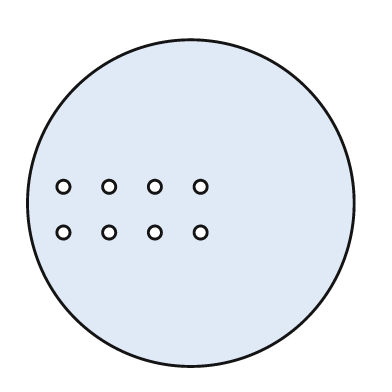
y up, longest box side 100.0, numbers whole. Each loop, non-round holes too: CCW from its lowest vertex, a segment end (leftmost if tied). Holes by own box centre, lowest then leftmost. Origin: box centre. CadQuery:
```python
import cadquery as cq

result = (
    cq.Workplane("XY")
    .moveTo(0.0, 0.0)
    .circle(50.0)
    .moveTo(-39.0, -9.0)
    .circle(2.0)
    .moveTo(-25.0, -9.0)
    .circle(2.0)
    .moveTo(-11.0, -9.0)
    .circle(2.0)
    .moveTo(3.0, -9.0)
    .circle(2.0)
    .moveTo(-39.0, 5.0)
    .circle(2.0)
    .moveTo(-25.0, 5.0)
    .circle(2.0)
    .moveTo(-11.0, 5.0)
    .circle(2.0)
    .moveTo(3.0, 5.0)
    .circle(2.0)
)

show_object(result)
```